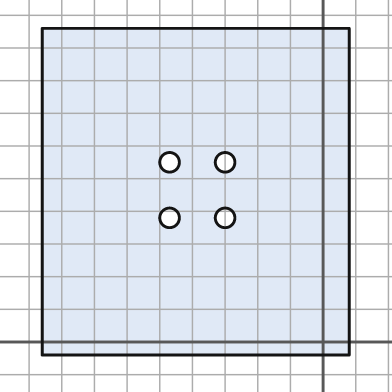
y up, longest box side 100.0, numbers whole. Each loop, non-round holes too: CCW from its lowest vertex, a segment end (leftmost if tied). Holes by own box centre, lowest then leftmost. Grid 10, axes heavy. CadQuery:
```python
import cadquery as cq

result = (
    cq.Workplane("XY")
    .moveTo(-86.0, -4.0)
    .lineTo(8.0, -4.0)
    .lineTo(8.0, 96.0)
    .lineTo(-86.0, 96.0)
    .close()
    .moveTo(-47.0, 38.0)
    .circle(3.0)
    .moveTo(-30.0, 38.0)
    .circle(3.0)
    .moveTo(-47.0, 55.0)
    .circle(3.0)
    .moveTo(-30.0, 55.0)
    .circle(3.0)
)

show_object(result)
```